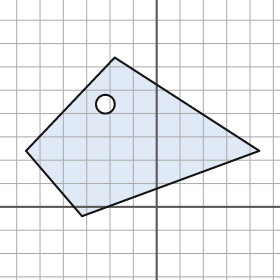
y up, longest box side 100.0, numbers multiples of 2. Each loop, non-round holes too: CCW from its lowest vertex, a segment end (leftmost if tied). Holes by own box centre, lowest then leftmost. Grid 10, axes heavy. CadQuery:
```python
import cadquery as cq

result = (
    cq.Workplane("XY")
    .moveTo(-32.0, -4.0)
    .lineTo(44.0, 24.0)
    .lineTo(-18.0, 64.0)
    .lineTo(-56.0, 24.0)
    .close()
    .moveTo(-22.0, 44.0)
    .circle(4.0)
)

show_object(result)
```